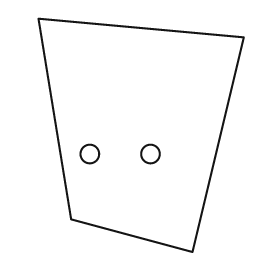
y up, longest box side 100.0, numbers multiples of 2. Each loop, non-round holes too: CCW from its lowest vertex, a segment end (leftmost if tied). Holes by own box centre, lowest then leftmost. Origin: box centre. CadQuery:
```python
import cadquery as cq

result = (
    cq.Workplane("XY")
    .moveTo(22.0, -50.0)
    .lineTo(44.0, 42.0)
    .lineTo(-44.0, 50.0)
    .lineTo(-30.0, -36.0)
    .close()
    .moveTo(-22.0, -8.0)
    .circle(4.0)
    .moveTo(4.0, -8.0)
    .circle(4.0)
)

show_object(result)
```